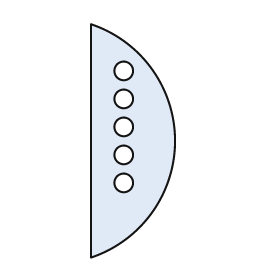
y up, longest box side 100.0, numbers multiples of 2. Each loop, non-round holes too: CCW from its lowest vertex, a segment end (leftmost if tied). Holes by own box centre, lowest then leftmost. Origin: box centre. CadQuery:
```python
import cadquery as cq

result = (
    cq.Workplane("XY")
    .moveTo(-18.0, -50.0)
    .threePointArc((18.0, 0.0), (-18.0, 50.0))
    .close()
    .moveTo(-4.0, -18.0)
    .circle(4.0)
    .moveTo(-4.0, -6.0)
    .circle(4.0)
    .moveTo(-4.0, 6.0)
    .circle(4.0)
    .moveTo(-4.0, 18.0)
    .circle(4.0)
    .moveTo(-4.0, 30.0)
    .circle(4.0)
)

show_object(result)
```